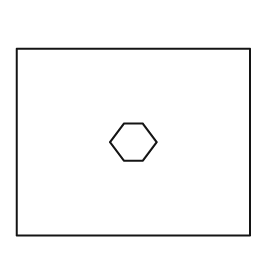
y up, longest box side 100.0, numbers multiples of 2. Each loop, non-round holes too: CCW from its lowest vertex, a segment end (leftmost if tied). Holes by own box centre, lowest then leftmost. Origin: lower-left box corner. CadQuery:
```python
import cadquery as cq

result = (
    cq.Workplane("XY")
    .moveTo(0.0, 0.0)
    .lineTo(100.0, 0.0)
    .lineTo(100.0, 80.0)
    .lineTo(0.0, 80.0)
    .close()
    .moveTo(46.0, 32.0)
    .lineTo(54.0, 32.0)
    .lineTo(60.0, 40.0)
    .lineTo(54.0, 48.0)
    .lineTo(46.0, 48.0)
    .lineTo(40.0, 40.0)
    .close()
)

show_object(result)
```